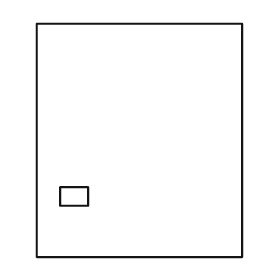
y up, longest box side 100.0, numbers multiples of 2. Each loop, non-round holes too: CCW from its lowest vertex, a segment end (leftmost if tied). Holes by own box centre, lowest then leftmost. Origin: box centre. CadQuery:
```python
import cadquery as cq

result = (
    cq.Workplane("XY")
    .moveTo(-44.0, -50.0)
    .lineTo(44.0, -50.0)
    .lineTo(44.0, 50.0)
    .lineTo(-44.0, 50.0)
    .close()
    .moveTo(-34.0, -28.0)
    .lineTo(-22.0, -28.0)
    .lineTo(-22.0, -20.0)
    .lineTo(-34.0, -20.0)
    .close()
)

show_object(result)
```